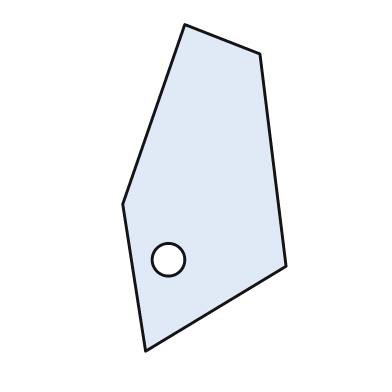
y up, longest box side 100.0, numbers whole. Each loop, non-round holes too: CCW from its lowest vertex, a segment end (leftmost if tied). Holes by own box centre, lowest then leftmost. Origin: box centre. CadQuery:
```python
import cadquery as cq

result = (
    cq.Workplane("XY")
    .moveTo(-18.0, -50.0)
    .lineTo(25.0, -24.0)
    .lineTo(17.0, 41.0)
    .lineTo(-6.0, 50.0)
    .lineTo(-25.0, -5.0)
    .close()
    .moveTo(-11.0, -22.0)
    .circle(5.0)
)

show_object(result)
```